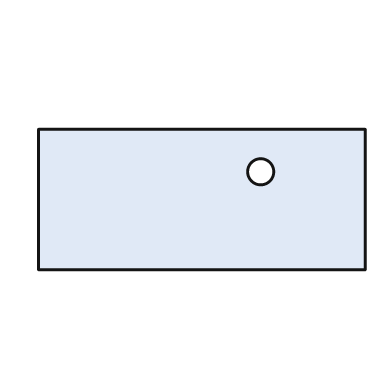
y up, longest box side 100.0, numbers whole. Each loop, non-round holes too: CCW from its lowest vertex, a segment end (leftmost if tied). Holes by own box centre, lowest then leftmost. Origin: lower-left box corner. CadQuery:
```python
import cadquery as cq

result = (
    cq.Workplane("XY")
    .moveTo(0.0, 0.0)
    .lineTo(100.0, 0.0)
    .lineTo(100.0, 43.0)
    .lineTo(0.0, 43.0)
    .close()
    .moveTo(68.0, 30.0)
    .circle(4.0)
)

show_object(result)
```